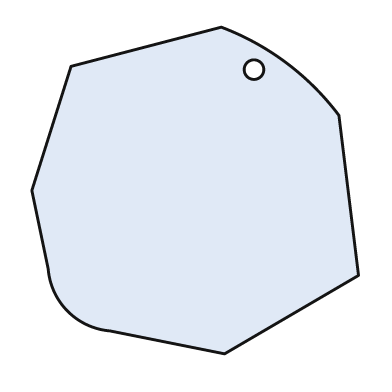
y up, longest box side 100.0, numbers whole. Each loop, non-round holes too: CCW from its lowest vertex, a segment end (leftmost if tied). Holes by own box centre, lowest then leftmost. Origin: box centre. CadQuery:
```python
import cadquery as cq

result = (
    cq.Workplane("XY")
    .moveTo(9.0, -50.0)
    .lineTo(50.0, -26.0)
    .lineTo(44.0, 23.0)
    .threePointArc((28.0, 39.0), (8.0, 50.0))
    .lineTo(-38.0, 38.0)
    .lineTo(-50.0, 0.0)
    .lineTo(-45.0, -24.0)
    .threePointArc((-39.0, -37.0), (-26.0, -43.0))
    .close()
    .moveTo(18.0, 37.0)
    .circle(3.0)
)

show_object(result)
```